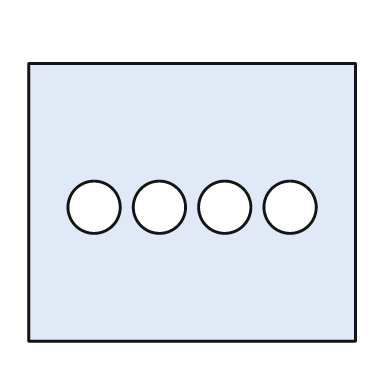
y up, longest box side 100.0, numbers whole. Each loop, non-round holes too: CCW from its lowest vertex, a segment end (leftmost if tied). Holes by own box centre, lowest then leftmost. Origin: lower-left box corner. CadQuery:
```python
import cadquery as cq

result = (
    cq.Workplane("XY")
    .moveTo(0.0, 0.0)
    .lineTo(100.0, 0.0)
    .lineTo(100.0, 85.0)
    .lineTo(0.0, 85.0)
    .close()
    .moveTo(20.0, 41.0)
    .circle(8.0)
    .moveTo(40.0, 41.0)
    .circle(8.0)
    .moveTo(60.0, 41.0)
    .circle(8.0)
    .moveTo(80.0, 41.0)
    .circle(8.0)
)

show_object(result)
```